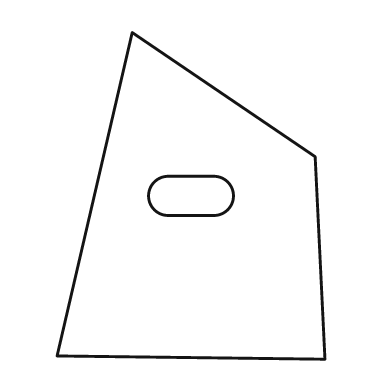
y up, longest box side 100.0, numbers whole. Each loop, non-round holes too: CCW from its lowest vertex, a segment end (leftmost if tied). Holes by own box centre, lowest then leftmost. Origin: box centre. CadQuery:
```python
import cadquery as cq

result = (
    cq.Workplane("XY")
    .moveTo(41.0, -50.0)
    .lineTo(38.0, 12.0)
    .lineTo(-18.0, 50.0)
    .lineTo(-41.0, -49.0)
    .close()
    .moveTo(-7.0, -6.0)
    .lineTo(7.0, -6.0)
    .threePointArc((13.0, 0.0), (7.0, 6.0))
    .lineTo(-7.0, 6.0)
    .threePointArc((-13.0, 0.0), (-7.0, -6.0))
    .close()
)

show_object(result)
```